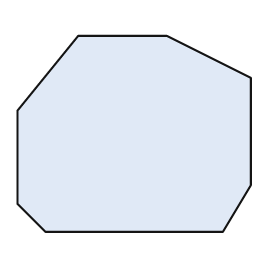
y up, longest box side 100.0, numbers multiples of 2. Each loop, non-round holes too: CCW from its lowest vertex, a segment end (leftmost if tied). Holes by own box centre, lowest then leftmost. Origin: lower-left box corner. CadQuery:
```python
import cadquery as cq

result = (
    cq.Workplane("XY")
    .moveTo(12.0, 0.0)
    .lineTo(88.0, 0.0)
    .lineTo(100.0, 20.0)
    .lineTo(100.0, 66.0)
    .lineTo(64.0, 84.0)
    .lineTo(26.0, 84.0)
    .lineTo(0.0, 52.0)
    .lineTo(0.0, 12.0)
    .close()
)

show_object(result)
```